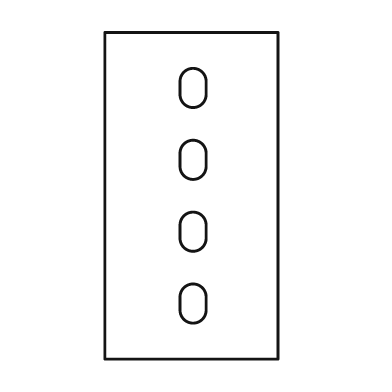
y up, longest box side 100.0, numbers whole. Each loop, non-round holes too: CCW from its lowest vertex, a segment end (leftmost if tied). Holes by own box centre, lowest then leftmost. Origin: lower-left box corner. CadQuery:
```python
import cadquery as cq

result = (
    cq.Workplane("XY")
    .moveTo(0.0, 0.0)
    .lineTo(53.0, 0.0)
    .lineTo(53.0, 100.0)
    .lineTo(0.0, 100.0)
    .close()
    .moveTo(23.0, 15.0)
    .threePointArc((27.0, 11.0), (31.0, 15.0))
    .lineTo(31.0, 19.0)
    .threePointArc((27.0, 23.0), (23.0, 19.0))
    .close()
    .moveTo(23.0, 37.0)
    .threePointArc((27.0, 33.0), (31.0, 37.0))
    .lineTo(31.0, 41.0)
    .threePointArc((27.0, 45.0), (23.0, 41.0))
    .close()
    .moveTo(23.0, 59.0)
    .threePointArc((27.0, 55.0), (31.0, 59.0))
    .lineTo(31.0, 63.0)
    .threePointArc((27.0, 67.0), (23.0, 63.0))
    .close()
    .moveTo(23.0, 81.0)
    .threePointArc((27.0, 77.0), (31.0, 81.0))
    .lineTo(31.0, 85.0)
    .threePointArc((27.0, 89.0), (23.0, 85.0))
    .close()
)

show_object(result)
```